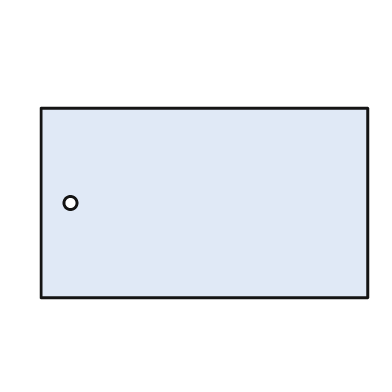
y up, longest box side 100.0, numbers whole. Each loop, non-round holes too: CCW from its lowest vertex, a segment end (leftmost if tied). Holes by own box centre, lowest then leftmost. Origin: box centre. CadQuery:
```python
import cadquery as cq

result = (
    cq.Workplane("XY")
    .moveTo(-50.0, -29.0)
    .lineTo(50.0, -29.0)
    .lineTo(50.0, 29.0)
    .lineTo(-50.0, 29.0)
    .close()
    .moveTo(-41.0, 0.0)
    .circle(2.0)
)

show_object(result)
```